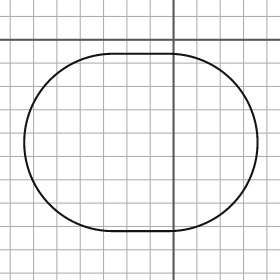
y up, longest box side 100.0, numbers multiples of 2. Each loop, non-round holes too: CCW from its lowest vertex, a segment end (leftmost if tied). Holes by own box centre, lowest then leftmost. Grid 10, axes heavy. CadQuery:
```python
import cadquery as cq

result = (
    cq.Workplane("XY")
    .moveTo(-26.0, -82.0)
    .lineTo(-2.0, -82.0)
    .threePointArc((36.0, -44.0), (-2.0, -6.0))
    .lineTo(-26.0, -6.0)
    .threePointArc((-64.0, -44.0), (-26.0, -82.0))
    .close()
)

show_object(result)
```